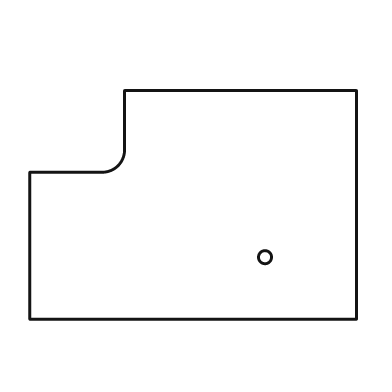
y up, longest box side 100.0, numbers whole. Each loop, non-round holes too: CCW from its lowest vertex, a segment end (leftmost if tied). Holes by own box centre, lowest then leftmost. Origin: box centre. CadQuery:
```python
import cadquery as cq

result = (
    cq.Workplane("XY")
    .moveTo(-50.0, -35.0)
    .lineTo(50.0, -35.0)
    .lineTo(50.0, 35.0)
    .lineTo(-21.0, 35.0)
    .lineTo(-21.0, 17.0)
    .threePointArc((-23.0, 12.0), (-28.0, 10.0))
    .lineTo(-50.0, 10.0)
    .close()
    .moveTo(22.0, -16.0)
    .circle(2.0)
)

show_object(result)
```